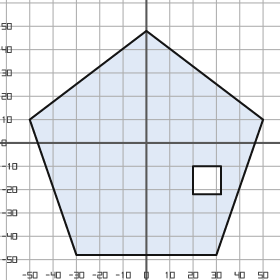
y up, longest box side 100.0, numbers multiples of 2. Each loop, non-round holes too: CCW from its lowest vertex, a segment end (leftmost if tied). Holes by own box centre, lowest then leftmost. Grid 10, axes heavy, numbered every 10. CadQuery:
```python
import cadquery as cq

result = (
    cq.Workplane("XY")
    .moveTo(-30.0, -48.0)
    .lineTo(30.0, -48.0)
    .lineTo(50.0, 10.0)
    .lineTo(0.0, 48.0)
    .lineTo(-50.0, 10.0)
    .close()
    .moveTo(20.0, -22.0)
    .lineTo(32.0, -22.0)
    .lineTo(32.0, -10.0)
    .lineTo(20.0, -10.0)
    .close()
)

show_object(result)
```